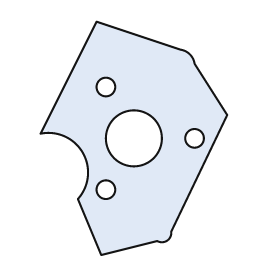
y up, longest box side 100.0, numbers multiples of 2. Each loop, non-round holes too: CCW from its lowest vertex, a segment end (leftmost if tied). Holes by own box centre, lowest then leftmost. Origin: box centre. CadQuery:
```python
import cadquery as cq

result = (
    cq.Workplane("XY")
    .moveTo(-14.0, -50.0)
    .lineTo(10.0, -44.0)
    .threePointArc((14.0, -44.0), (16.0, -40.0))
    .lineTo(40.0, 10.0)
    .lineTo(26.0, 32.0)
    .threePointArc((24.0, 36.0), (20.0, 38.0))
    .lineTo(-16.0, 50.0)
    .lineTo(-40.0, 2.0)
    .threePointArc((-22.0, -6.0), (-24.0, -26.0))
    .close()
    .moveTo(-12.0, -22.0)
    .circle(4.0)
    .moveTo(0.0, 0.0)
    .circle(12.0)
    .moveTo(26.0, 0.0)
    .circle(4.0)
    .moveTo(-12.0, 22.0)
    .circle(4.0)
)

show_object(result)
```